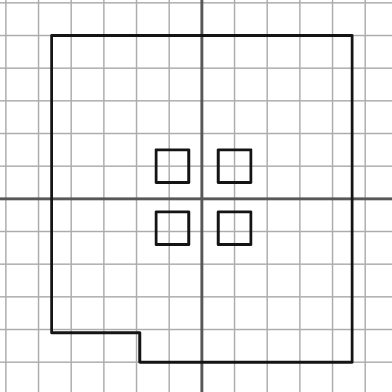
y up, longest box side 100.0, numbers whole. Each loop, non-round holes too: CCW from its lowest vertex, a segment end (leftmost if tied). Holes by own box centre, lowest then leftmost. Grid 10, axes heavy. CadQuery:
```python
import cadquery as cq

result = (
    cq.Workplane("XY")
    .moveTo(-19.0, -50.0)
    .lineTo(46.0, -50.0)
    .lineTo(46.0, 50.0)
    .lineTo(-46.0, 50.0)
    .lineTo(-46.0, -41.0)
    .lineTo(-19.0, -41.0)
    .close()
    .moveTo(-14.0, -14.0)
    .lineTo(-4.0, -14.0)
    .lineTo(-4.0, -4.0)
    .lineTo(-14.0, -4.0)
    .close()
    .moveTo(5.0, -14.0)
    .lineTo(15.0, -14.0)
    .lineTo(15.0, -4.0)
    .lineTo(5.0, -4.0)
    .close()
    .moveTo(-14.0, 5.0)
    .lineTo(-4.0, 5.0)
    .lineTo(-4.0, 15.0)
    .lineTo(-14.0, 15.0)
    .close()
    .moveTo(5.0, 5.0)
    .lineTo(15.0, 5.0)
    .lineTo(15.0, 15.0)
    .lineTo(5.0, 15.0)
    .close()
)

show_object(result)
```